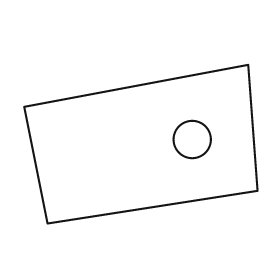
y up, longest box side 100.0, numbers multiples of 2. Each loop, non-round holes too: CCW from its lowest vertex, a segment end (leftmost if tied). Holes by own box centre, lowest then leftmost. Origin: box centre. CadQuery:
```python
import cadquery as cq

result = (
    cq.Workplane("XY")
    .moveTo(-40.0, -34.0)
    .lineTo(50.0, -20.0)
    .lineTo(46.0, 34.0)
    .lineTo(-50.0, 16.0)
    .close()
    .moveTo(22.0, 2.0)
    .circle(8.0)
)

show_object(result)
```